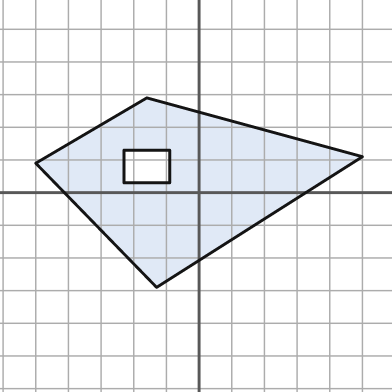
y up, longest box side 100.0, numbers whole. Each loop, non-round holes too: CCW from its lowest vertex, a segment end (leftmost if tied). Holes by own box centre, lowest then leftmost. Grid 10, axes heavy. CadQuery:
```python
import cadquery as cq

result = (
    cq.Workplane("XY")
    .moveTo(-13.0, -29.0)
    .lineTo(50.0, 11.0)
    .lineTo(-16.0, 29.0)
    .lineTo(-50.0, 9.0)
    .close()
    .moveTo(-23.0, 3.0)
    .lineTo(-9.0, 3.0)
    .lineTo(-9.0, 13.0)
    .lineTo(-23.0, 13.0)
    .close()
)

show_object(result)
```